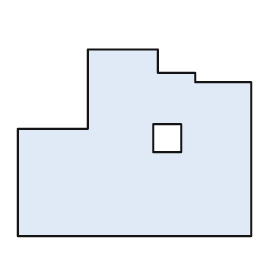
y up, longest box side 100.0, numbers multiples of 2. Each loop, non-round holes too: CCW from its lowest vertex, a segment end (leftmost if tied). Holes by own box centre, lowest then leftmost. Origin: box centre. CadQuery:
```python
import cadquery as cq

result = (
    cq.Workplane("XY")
    .moveTo(-50.0, -40.0)
    .lineTo(50.0, -40.0)
    .lineTo(50.0, 26.0)
    .lineTo(26.0, 26.0)
    .lineTo(26.0, 30.0)
    .lineTo(10.0, 30.0)
    .lineTo(10.0, 40.0)
    .lineTo(-20.0, 40.0)
    .lineTo(-20.0, 6.0)
    .lineTo(-50.0, 6.0)
    .close()
    .moveTo(8.0, -4.0)
    .lineTo(20.0, -4.0)
    .lineTo(20.0, 8.0)
    .lineTo(8.0, 8.0)
    .close()
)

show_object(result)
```